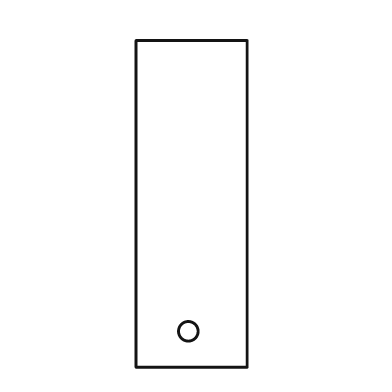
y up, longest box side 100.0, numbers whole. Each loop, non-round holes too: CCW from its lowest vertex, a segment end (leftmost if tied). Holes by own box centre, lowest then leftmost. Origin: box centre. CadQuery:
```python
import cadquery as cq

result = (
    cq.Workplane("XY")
    .moveTo(-17.0, -50.0)
    .lineTo(17.0, -50.0)
    .lineTo(17.0, 50.0)
    .lineTo(-17.0, 50.0)
    .close()
    .moveTo(-1.0, -39.0)
    .circle(3.0)
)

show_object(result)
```